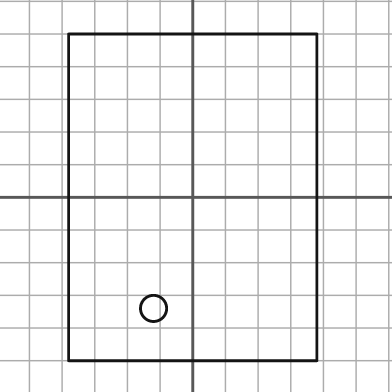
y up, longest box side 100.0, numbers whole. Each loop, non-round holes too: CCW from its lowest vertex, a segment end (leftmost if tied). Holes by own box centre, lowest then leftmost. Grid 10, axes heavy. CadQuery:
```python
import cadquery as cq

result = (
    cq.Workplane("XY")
    .moveTo(-38.0, -50.0)
    .lineTo(38.0, -50.0)
    .lineTo(38.0, 50.0)
    .lineTo(-38.0, 50.0)
    .close()
    .moveTo(-12.0, -34.0)
    .circle(4.0)
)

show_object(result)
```